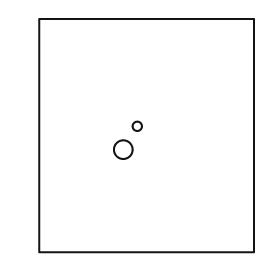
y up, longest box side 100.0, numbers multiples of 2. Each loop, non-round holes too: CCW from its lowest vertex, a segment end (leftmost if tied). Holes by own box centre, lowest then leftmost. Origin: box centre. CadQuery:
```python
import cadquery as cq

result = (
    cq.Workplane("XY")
    .moveTo(-46.0, -50.0)
    .lineTo(46.0, -50.0)
    .lineTo(46.0, 50.0)
    .lineTo(-46.0, 50.0)
    .close()
    .moveTo(-10.0, -6.0)
    .circle(4.0)
    .moveTo(-4.0, 4.0)
    .circle(2.0)
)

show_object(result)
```